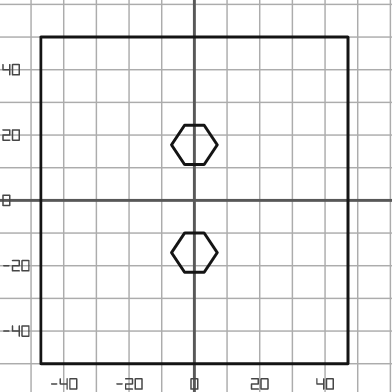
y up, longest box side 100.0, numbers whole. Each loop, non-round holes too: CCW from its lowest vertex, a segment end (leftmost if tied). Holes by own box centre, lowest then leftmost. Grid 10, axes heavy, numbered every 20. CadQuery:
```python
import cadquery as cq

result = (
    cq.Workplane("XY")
    .moveTo(-47.0, -50.0)
    .lineTo(47.0, -50.0)
    .lineTo(47.0, 50.0)
    .lineTo(-47.0, 50.0)
    .close()
    .moveTo(-3.0, -22.0)
    .lineTo(3.0, -22.0)
    .lineTo(7.0, -16.0)
    .lineTo(3.0, -10.0)
    .lineTo(-3.0, -10.0)
    .lineTo(-7.0, -16.0)
    .close()
    .moveTo(-3.0, 11.0)
    .lineTo(3.0, 11.0)
    .lineTo(7.0, 17.0)
    .lineTo(3.0, 23.0)
    .lineTo(-3.0, 23.0)
    .lineTo(-7.0, 17.0)
    .close()
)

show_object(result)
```